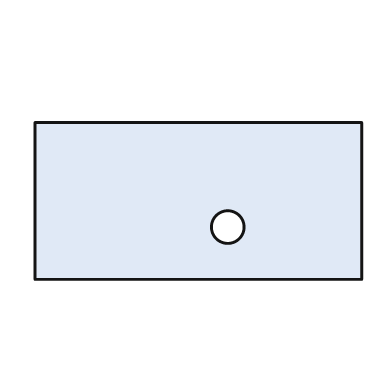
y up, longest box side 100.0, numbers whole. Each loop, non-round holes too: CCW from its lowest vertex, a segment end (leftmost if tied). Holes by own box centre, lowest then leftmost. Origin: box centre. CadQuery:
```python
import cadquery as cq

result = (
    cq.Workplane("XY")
    .moveTo(-50.0, -24.0)
    .lineTo(50.0, -24.0)
    .lineTo(50.0, 24.0)
    .lineTo(-50.0, 24.0)
    .close()
    .moveTo(9.0, -8.0)
    .circle(5.0)
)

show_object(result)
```